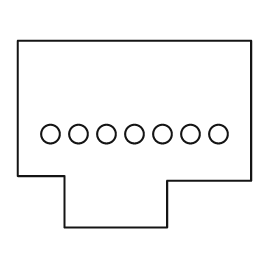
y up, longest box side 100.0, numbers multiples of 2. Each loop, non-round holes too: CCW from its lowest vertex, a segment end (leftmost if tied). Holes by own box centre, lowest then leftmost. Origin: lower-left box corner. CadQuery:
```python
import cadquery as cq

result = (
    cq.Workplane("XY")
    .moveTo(20.0, 0.0)
    .lineTo(64.0, 0.0)
    .lineTo(64.0, 20.0)
    .lineTo(100.0, 20.0)
    .lineTo(100.0, 80.0)
    .lineTo(0.0, 80.0)
    .lineTo(0.0, 22.0)
    .lineTo(20.0, 22.0)
    .close()
    .moveTo(14.0, 40.0)
    .circle(4.0)
    .moveTo(26.0, 40.0)
    .circle(4.0)
    .moveTo(38.0, 40.0)
    .circle(4.0)
    .moveTo(50.0, 40.0)
    .circle(4.0)
    .moveTo(62.0, 40.0)
    .circle(4.0)
    .moveTo(74.0, 40.0)
    .circle(4.0)
    .moveTo(86.0, 40.0)
    .circle(4.0)
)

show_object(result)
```